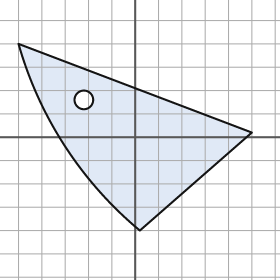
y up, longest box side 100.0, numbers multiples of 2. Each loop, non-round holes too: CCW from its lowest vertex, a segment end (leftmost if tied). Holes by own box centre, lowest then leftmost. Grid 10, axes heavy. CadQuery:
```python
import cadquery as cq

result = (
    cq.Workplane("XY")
    .moveTo(2.0, -40.0)
    .lineTo(50.0, 2.0)
    .lineTo(-50.0, 40.0)
    .threePointArc((-30.0, -4.0), (2.0, -40.0))
    .close()
    .moveTo(-22.0, 16.0)
    .circle(4.0)
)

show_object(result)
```